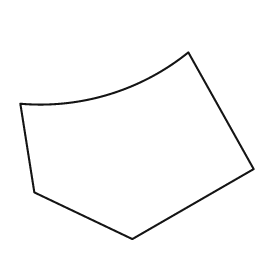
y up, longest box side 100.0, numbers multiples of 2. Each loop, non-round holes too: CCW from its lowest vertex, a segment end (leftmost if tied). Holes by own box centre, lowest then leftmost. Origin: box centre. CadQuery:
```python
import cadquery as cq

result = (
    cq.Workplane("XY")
    .moveTo(-2.0, -40.0)
    .lineTo(50.0, -10.0)
    .lineTo(22.0, 40.0)
    .threePointArc((-12.0, 22.0), (-50.0, 18.0))
    .lineTo(-44.0, -20.0)
    .close()
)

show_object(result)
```